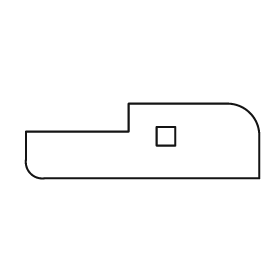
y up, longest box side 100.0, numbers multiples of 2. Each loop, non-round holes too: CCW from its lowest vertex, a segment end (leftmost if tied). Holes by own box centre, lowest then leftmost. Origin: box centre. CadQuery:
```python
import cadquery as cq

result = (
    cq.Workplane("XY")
    .moveTo(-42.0, -16.0)
    .lineTo(50.0, -16.0)
    .lineTo(50.0, 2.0)
    .threePointArc((46.0, 12.0), (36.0, 16.0))
    .lineTo(-6.0, 16.0)
    .lineTo(-6.0, 4.0)
    .lineTo(-50.0, 4.0)
    .lineTo(-50.0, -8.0)
    .threePointArc((-48.0, -14.0), (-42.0, -16.0))
    .close()
    .moveTo(6.0, -2.0)
    .lineTo(14.0, -2.0)
    .lineTo(14.0, 6.0)
    .lineTo(6.0, 6.0)
    .close()
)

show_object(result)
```